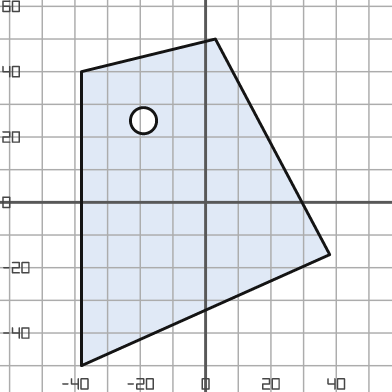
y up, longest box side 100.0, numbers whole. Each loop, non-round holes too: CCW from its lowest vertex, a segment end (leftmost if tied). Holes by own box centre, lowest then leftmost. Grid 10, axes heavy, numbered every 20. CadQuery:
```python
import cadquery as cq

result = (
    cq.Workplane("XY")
    .moveTo(-38.0, -50.0)
    .lineTo(38.0, -16.0)
    .lineTo(3.0, 50.0)
    .lineTo(-38.0, 40.0)
    .close()
    .moveTo(-19.0, 25.0)
    .circle(4.0)
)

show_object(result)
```